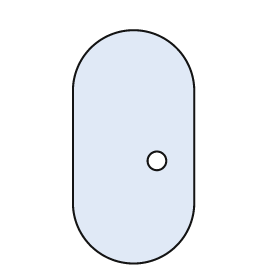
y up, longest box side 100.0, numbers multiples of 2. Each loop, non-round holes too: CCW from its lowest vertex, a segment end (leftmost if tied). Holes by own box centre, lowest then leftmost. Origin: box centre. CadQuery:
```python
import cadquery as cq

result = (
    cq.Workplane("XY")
    .moveTo(-26.0, -24.0)
    .threePointArc((0.0, -50.0), (26.0, -24.0))
    .lineTo(26.0, 24.0)
    .threePointArc((0.0, 50.0), (-26.0, 24.0))
    .close()
    .moveTo(10.0, -6.0)
    .circle(4.0)
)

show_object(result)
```